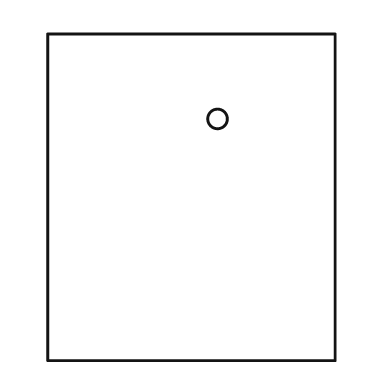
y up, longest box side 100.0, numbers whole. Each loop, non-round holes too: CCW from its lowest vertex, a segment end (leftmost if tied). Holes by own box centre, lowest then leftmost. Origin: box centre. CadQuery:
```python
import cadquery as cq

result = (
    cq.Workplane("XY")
    .moveTo(-44.0, -50.0)
    .lineTo(44.0, -50.0)
    .lineTo(44.0, 50.0)
    .lineTo(-44.0, 50.0)
    .close()
    .moveTo(8.0, 24.0)
    .circle(3.0)
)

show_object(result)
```